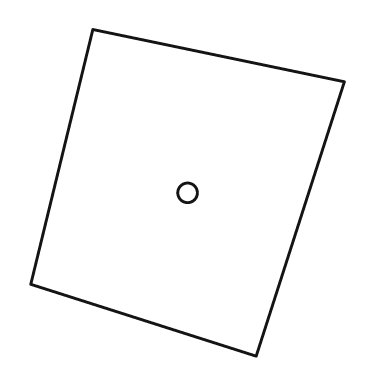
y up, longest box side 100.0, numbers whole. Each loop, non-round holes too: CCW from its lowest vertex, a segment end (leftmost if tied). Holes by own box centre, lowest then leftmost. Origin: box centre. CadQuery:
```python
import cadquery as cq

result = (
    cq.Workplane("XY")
    .moveTo(21.0, -50.0)
    .lineTo(48.0, 34.0)
    .lineTo(-29.0, 50.0)
    .lineTo(-48.0, -28.0)
    .close()
    .moveTo(0.0, 0.0)
    .circle(3.0)
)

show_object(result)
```